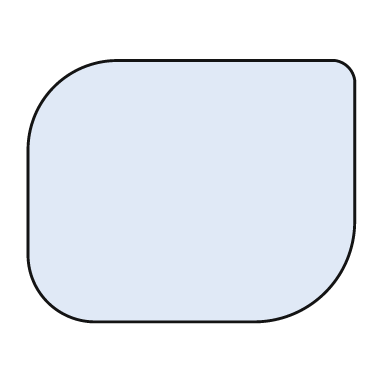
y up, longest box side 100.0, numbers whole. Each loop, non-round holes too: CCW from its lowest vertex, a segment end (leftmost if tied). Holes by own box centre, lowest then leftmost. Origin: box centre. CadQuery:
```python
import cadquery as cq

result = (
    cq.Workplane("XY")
    .moveTo(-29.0, -40.0)
    .lineTo(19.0, -40.0)
    .threePointArc((41.0, -31.0), (50.0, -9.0))
    .lineTo(50.0, 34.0)
    .threePointArc((48.0, 38.0), (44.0, 40.0))
    .lineTo(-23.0, 40.0)
    .threePointArc((-42.0, 32.0), (-50.0, 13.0))
    .lineTo(-50.0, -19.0)
    .threePointArc((-44.0, -34.0), (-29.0, -40.0))
    .close()
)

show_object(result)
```